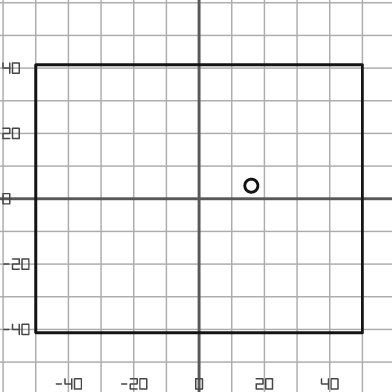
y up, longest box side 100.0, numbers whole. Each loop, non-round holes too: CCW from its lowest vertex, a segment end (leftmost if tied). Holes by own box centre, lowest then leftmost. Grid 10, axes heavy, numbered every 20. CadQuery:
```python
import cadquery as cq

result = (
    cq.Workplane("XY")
    .moveTo(-50.0, -41.0)
    .lineTo(50.0, -41.0)
    .lineTo(50.0, 41.0)
    .lineTo(-50.0, 41.0)
    .close()
    .moveTo(16.0, 4.0)
    .circle(2.0)
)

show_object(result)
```